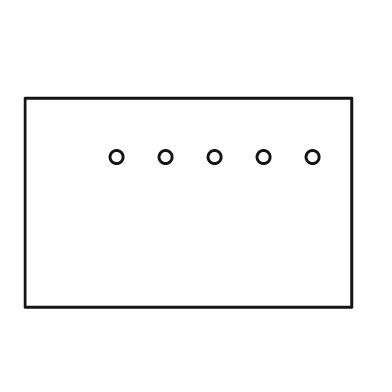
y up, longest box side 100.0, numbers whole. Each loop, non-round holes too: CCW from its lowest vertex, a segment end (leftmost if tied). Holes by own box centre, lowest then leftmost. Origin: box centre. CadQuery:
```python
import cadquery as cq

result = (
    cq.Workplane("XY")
    .moveTo(-50.0, -32.0)
    .lineTo(50.0, -32.0)
    .lineTo(50.0, 32.0)
    .lineTo(-50.0, 32.0)
    .close()
    .moveTo(-22.0, 14.0)
    .circle(2.0)
    .moveTo(-7.0, 14.0)
    .circle(2.0)
    .moveTo(8.0, 14.0)
    .circle(2.0)
    .moveTo(23.0, 14.0)
    .circle(2.0)
    .moveTo(38.0, 14.0)
    .circle(2.0)
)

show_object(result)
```